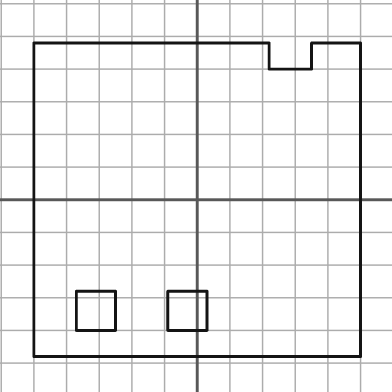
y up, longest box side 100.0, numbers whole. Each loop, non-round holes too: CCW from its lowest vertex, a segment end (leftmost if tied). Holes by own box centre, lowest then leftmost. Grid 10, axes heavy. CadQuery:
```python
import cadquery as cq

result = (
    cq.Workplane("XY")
    .moveTo(-50.0, -48.0)
    .lineTo(50.0, -48.0)
    .lineTo(50.0, 48.0)
    .lineTo(35.0, 48.0)
    .lineTo(35.0, 40.0)
    .lineTo(22.0, 40.0)
    .lineTo(22.0, 48.0)
    .lineTo(-50.0, 48.0)
    .close()
    .moveTo(-37.0, -40.0)
    .lineTo(-25.0, -40.0)
    .lineTo(-25.0, -28.0)
    .lineTo(-37.0, -28.0)
    .close()
    .moveTo(-9.0, -40.0)
    .lineTo(3.0, -40.0)
    .lineTo(3.0, -28.0)
    .lineTo(-9.0, -28.0)
    .close()
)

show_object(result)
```